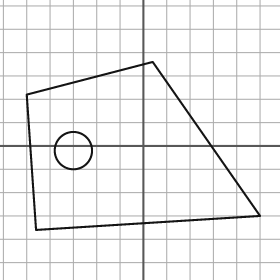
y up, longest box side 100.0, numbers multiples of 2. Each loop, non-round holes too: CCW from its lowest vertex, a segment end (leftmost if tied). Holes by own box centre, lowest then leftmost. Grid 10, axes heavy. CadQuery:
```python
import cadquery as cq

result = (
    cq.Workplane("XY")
    .moveTo(-46.0, -36.0)
    .lineTo(50.0, -30.0)
    .lineTo(4.0, 36.0)
    .lineTo(-50.0, 22.0)
    .close()
    .moveTo(-30.0, -2.0)
    .circle(8.0)
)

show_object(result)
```